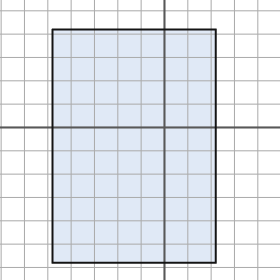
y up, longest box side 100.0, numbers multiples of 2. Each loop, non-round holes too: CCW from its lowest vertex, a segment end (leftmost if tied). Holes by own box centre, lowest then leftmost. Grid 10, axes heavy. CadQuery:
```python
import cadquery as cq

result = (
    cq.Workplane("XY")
    .moveTo(-48.0, -58.0)
    .lineTo(22.0, -58.0)
    .lineTo(22.0, 42.0)
    .lineTo(-48.0, 42.0)
    .close()
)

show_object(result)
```